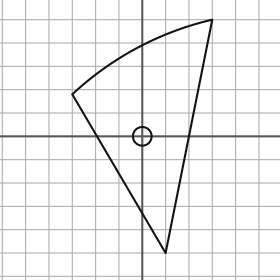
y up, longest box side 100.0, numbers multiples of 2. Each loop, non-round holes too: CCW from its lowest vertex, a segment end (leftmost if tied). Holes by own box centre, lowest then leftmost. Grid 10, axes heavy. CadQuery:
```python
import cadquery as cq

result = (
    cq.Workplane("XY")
    .moveTo(10.0, -50.0)
    .lineTo(30.0, 50.0)
    .threePointArc((-2.0, 38.0), (-30.0, 18.0))
    .close()
    .moveTo(0.0, 0.0)
    .circle(4.0)
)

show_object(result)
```